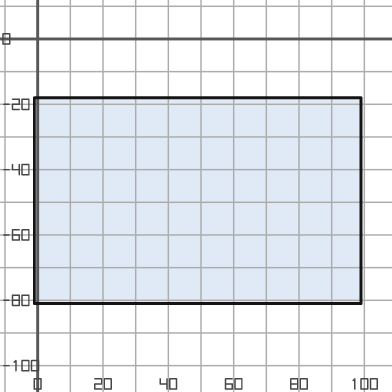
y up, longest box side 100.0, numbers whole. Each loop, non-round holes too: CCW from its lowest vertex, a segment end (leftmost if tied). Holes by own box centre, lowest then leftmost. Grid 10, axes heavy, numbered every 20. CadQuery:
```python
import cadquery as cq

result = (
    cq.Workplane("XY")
    .moveTo(-1.0, -81.0)
    .lineTo(99.0, -81.0)
    .lineTo(99.0, -18.0)
    .lineTo(-1.0, -18.0)
    .close()
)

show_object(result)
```